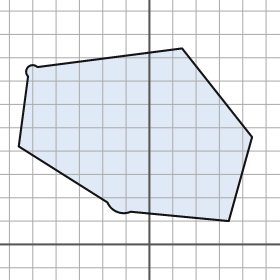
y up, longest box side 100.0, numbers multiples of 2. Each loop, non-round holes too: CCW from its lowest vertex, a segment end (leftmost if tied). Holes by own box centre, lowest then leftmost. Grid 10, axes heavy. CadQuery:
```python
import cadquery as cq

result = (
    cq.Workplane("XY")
    .moveTo(34.0, 10.0)
    .lineTo(44.0, 46.0)
    .lineTo(14.0, 84.0)
    .lineTo(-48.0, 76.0)
    .threePointArc((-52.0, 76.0), (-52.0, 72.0))
    .lineTo(-56.0, 42.0)
    .lineTo(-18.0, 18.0)
    .threePointArc((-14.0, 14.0), (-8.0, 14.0))
    .close()
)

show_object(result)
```